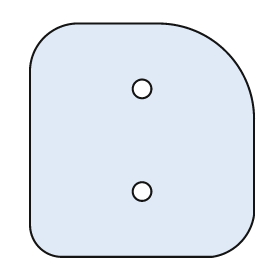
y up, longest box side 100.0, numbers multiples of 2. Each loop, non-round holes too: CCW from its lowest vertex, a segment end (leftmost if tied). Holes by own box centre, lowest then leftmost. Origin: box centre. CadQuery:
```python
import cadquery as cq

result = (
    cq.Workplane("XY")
    .moveTo(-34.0, -50.0)
    .lineTo(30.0, -50.0)
    .threePointArc((42.0, -44.0), (48.0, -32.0))
    .lineTo(48.0, 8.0)
    .threePointArc((36.0, 38.0), (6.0, 50.0))
    .lineTo(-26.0, 50.0)
    .threePointArc((-42.0, 44.0), (-48.0, 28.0))
    .lineTo(-48.0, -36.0)
    .threePointArc((-44.0, -46.0), (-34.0, -50.0))
    .close()
    .moveTo(0.0, -22.0)
    .circle(4.0)
    .moveTo(0.0, 22.0)
    .circle(4.0)
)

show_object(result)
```